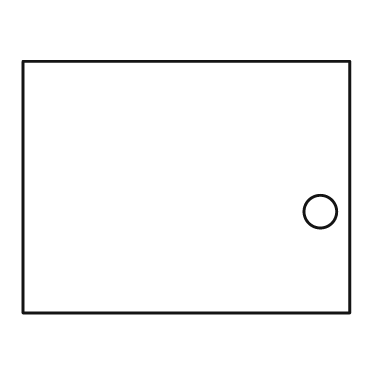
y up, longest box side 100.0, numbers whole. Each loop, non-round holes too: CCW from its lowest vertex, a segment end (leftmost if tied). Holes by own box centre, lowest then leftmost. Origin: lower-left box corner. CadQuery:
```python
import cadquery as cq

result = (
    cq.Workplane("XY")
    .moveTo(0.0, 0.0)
    .lineTo(100.0, 0.0)
    .lineTo(100.0, 77.0)
    .lineTo(0.0, 77.0)
    .close()
    .moveTo(91.0, 31.0)
    .circle(5.0)
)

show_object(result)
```